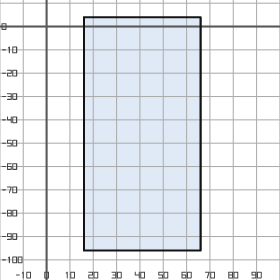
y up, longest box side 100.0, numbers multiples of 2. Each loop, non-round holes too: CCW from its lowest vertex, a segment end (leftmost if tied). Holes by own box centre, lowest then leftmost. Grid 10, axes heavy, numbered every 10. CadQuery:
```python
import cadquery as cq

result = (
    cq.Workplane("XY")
    .moveTo(16.0, -96.0)
    .lineTo(66.0, -96.0)
    .lineTo(66.0, 4.0)
    .lineTo(16.0, 4.0)
    .close()
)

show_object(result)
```